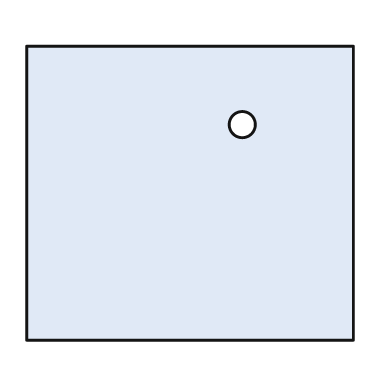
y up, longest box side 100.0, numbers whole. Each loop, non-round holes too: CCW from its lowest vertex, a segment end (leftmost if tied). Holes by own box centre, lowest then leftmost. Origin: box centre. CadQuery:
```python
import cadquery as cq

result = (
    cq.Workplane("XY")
    .moveTo(-50.0, -45.0)
    .lineTo(50.0, -45.0)
    .lineTo(50.0, 45.0)
    .lineTo(-50.0, 45.0)
    .close()
    .moveTo(16.0, 21.0)
    .circle(4.0)
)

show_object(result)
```